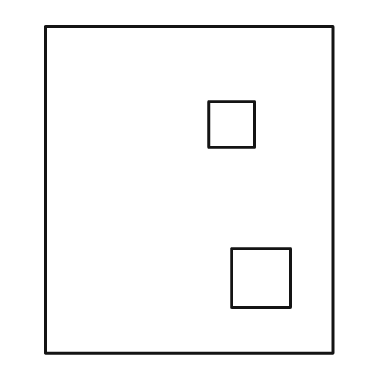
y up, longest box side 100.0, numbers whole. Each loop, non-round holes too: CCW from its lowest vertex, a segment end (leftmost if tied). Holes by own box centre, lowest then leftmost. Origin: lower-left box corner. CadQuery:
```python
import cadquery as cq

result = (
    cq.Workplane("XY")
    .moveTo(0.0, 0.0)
    .lineTo(88.0, 0.0)
    .lineTo(88.0, 100.0)
    .lineTo(0.0, 100.0)
    .close()
    .moveTo(57.0, 14.0)
    .lineTo(75.0, 14.0)
    .lineTo(75.0, 32.0)
    .lineTo(57.0, 32.0)
    .close()
    .moveTo(50.0, 63.0)
    .lineTo(64.0, 63.0)
    .lineTo(64.0, 77.0)
    .lineTo(50.0, 77.0)
    .close()
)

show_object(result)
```